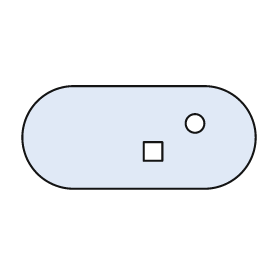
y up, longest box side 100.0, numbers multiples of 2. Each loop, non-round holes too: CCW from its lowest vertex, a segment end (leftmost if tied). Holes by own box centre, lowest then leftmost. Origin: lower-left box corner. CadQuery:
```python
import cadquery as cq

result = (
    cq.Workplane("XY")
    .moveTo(22.0, 0.0)
    .lineTo(78.0, 0.0)
    .threePointArc((100.0, 22.0), (78.0, 44.0))
    .lineTo(22.0, 44.0)
    .threePointArc((0.0, 22.0), (22.0, 0.0))
    .close()
    .moveTo(52.0, 12.0)
    .lineTo(60.0, 12.0)
    .lineTo(60.0, 20.0)
    .lineTo(52.0, 20.0)
    .close()
    .moveTo(74.0, 28.0)
    .circle(4.0)
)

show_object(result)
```